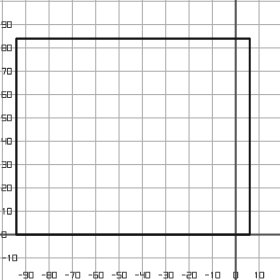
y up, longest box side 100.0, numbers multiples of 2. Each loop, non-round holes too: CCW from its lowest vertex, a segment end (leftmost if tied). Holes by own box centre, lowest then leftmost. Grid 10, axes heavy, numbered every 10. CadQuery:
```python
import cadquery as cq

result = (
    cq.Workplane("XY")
    .moveTo(-94.0, 0.0)
    .lineTo(6.0, 0.0)
    .lineTo(6.0, 84.0)
    .lineTo(-94.0, 84.0)
    .close()
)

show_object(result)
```